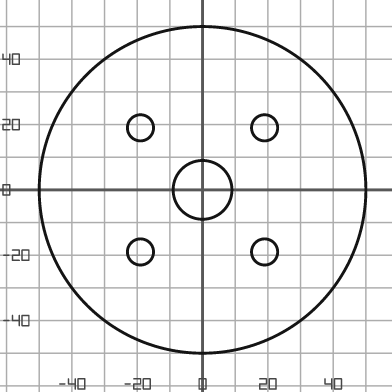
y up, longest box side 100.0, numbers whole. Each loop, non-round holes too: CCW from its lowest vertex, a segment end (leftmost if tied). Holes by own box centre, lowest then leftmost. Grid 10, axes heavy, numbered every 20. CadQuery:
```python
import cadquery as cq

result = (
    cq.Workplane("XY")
    .moveTo(0.0, 0.0)
    .circle(50.0)
    .moveTo(-19.0, -19.0)
    .circle(4.0)
    .moveTo(19.0, -19.0)
    .circle(4.0)
    .moveTo(0.0, 0.0)
    .circle(9.0)
    .moveTo(-19.0, 19.0)
    .circle(4.0)
    .moveTo(19.0, 19.0)
    .circle(4.0)
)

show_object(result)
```